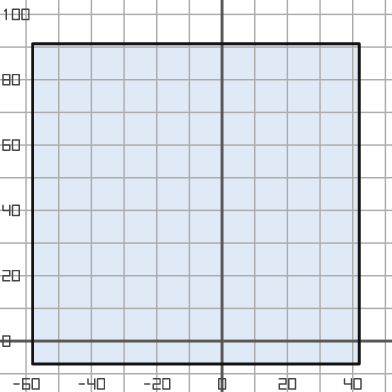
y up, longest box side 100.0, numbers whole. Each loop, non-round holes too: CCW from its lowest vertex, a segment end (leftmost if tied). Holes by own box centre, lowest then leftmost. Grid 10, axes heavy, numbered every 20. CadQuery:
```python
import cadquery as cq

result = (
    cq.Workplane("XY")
    .moveTo(-58.0, -7.0)
    .lineTo(42.0, -7.0)
    .lineTo(42.0, 91.0)
    .lineTo(-58.0, 91.0)
    .close()
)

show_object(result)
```